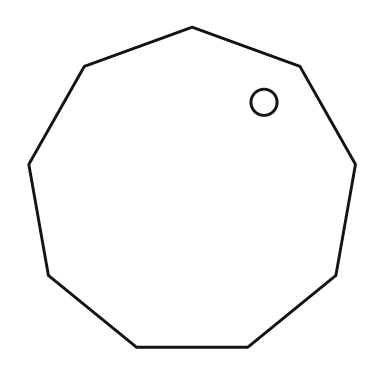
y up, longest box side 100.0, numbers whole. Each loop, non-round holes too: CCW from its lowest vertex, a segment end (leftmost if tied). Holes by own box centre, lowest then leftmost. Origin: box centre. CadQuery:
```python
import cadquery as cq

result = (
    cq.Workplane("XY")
    .moveTo(-17.0, -49.0)
    .lineTo(17.0, -49.0)
    .lineTo(44.0, -27.0)
    .lineTo(50.0, 7.0)
    .lineTo(33.0, 37.0)
    .lineTo(0.0, 49.0)
    .lineTo(-33.0, 37.0)
    .lineTo(-50.0, 7.0)
    .lineTo(-44.0, -27.0)
    .close()
    .moveTo(22.0, 26.0)
    .circle(4.0)
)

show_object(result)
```